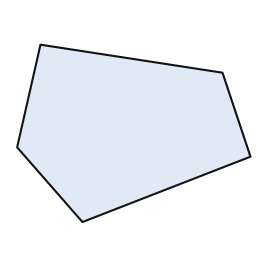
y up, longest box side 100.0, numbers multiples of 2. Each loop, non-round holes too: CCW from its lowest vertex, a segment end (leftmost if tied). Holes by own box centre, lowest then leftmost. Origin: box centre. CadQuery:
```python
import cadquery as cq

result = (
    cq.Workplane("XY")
    .moveTo(-22.0, -38.0)
    .lineTo(50.0, -10.0)
    .lineTo(38.0, 26.0)
    .lineTo(-40.0, 38.0)
    .lineTo(-50.0, -6.0)
    .close()
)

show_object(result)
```